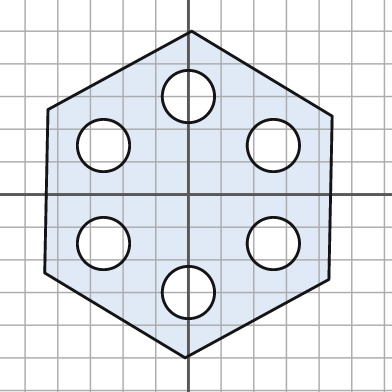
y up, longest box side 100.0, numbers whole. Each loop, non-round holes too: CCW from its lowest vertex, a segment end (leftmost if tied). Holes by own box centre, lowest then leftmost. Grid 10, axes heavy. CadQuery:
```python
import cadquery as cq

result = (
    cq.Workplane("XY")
    .moveTo(-1.0, -50.0)
    .lineTo(43.0, -26.0)
    .lineTo(44.0, 24.0)
    .lineTo(1.0, 50.0)
    .lineTo(-43.0, 26.0)
    .lineTo(-44.0, -24.0)
    .close()
    .moveTo(0.0, -30.0)
    .circle(8.0)
    .moveTo(-26.0, -15.0)
    .circle(8.0)
    .moveTo(26.0, -15.0)
    .circle(8.0)
    .moveTo(-26.0, 15.0)
    .circle(8.0)
    .moveTo(26.0, 15.0)
    .circle(8.0)
    .moveTo(0.0, 30.0)
    .circle(8.0)
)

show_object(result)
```